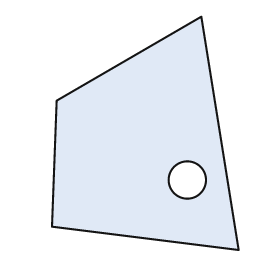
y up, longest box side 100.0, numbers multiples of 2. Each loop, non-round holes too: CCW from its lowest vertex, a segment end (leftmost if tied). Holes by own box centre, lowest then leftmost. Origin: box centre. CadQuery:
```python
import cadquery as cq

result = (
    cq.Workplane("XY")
    .moveTo(40.0, -50.0)
    .lineTo(24.0, 50.0)
    .lineTo(-38.0, 14.0)
    .lineTo(-40.0, -40.0)
    .close()
    .moveTo(18.0, -20.0)
    .circle(8.0)
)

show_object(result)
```